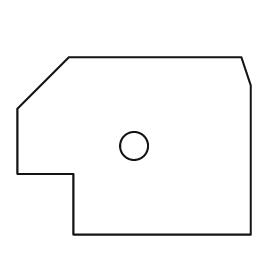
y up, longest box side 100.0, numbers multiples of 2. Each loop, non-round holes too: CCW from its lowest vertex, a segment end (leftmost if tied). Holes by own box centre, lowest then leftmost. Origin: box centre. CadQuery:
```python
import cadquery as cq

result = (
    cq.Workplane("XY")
    .moveTo(-26.0, -38.0)
    .lineTo(50.0, -38.0)
    .lineTo(50.0, 26.0)
    .lineTo(46.0, 38.0)
    .lineTo(-28.0, 38.0)
    .lineTo(-50.0, 16.0)
    .lineTo(-50.0, -12.0)
    .lineTo(-26.0, -12.0)
    .close()
    .moveTo(0.0, 0.0)
    .circle(6.0)
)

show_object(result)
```